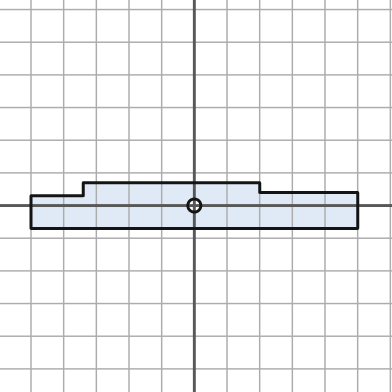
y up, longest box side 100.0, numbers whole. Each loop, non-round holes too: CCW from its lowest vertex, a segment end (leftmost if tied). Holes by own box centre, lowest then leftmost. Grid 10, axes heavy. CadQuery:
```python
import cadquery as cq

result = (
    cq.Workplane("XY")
    .moveTo(-50.0, -7.0)
    .lineTo(50.0, -7.0)
    .lineTo(50.0, 4.0)
    .lineTo(20.0, 4.0)
    .lineTo(20.0, 7.0)
    .lineTo(-34.0, 7.0)
    .lineTo(-34.0, 3.0)
    .lineTo(-50.0, 3.0)
    .close()
    .moveTo(0.0, 0.0)
    .circle(2.0)
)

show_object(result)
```